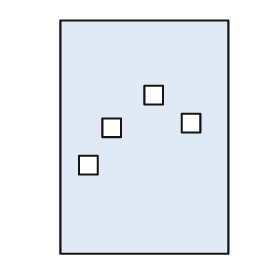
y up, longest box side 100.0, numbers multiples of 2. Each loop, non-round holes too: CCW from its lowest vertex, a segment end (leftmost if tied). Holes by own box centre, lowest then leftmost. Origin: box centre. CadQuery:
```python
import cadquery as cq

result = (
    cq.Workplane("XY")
    .moveTo(-36.0, -50.0)
    .lineTo(36.0, -50.0)
    .lineTo(36.0, 50.0)
    .lineTo(-36.0, 50.0)
    .close()
    .moveTo(-28.0, -16.0)
    .lineTo(-20.0, -16.0)
    .lineTo(-20.0, -8.0)
    .lineTo(-28.0, -8.0)
    .close()
    .moveTo(-18.0, 0.0)
    .lineTo(-10.0, 0.0)
    .lineTo(-10.0, 8.0)
    .lineTo(-18.0, 8.0)
    .close()
    .moveTo(16.0, 2.0)
    .lineTo(24.0, 2.0)
    .lineTo(24.0, 10.0)
    .lineTo(16.0, 10.0)
    .close()
    .moveTo(0.0, 14.0)
    .lineTo(8.0, 14.0)
    .lineTo(8.0, 22.0)
    .lineTo(0.0, 22.0)
    .close()
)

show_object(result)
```